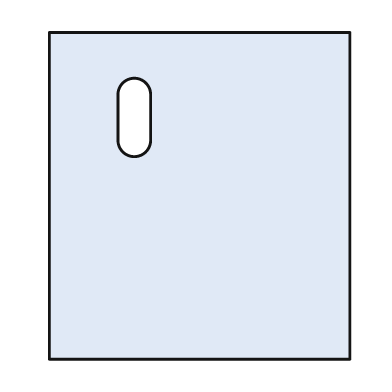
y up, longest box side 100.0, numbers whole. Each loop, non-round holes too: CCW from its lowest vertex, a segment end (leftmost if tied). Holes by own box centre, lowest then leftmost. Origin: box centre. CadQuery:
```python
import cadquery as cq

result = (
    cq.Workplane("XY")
    .moveTo(-46.0, -50.0)
    .lineTo(46.0, -50.0)
    .lineTo(46.0, 50.0)
    .lineTo(-46.0, 50.0)
    .close()
    .moveTo(-25.0, 17.0)
    .threePointArc((-20.0, 12.0), (-15.0, 17.0))
    .lineTo(-15.0, 31.0)
    .threePointArc((-20.0, 36.0), (-25.0, 31.0))
    .close()
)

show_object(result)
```